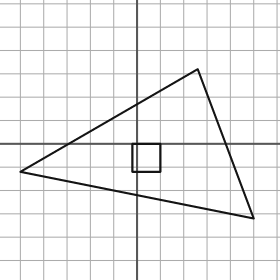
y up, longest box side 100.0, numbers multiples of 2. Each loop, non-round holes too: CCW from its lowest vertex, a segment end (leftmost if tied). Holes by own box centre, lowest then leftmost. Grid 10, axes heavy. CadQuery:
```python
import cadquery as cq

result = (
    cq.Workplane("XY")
    .moveTo(50.0, -32.0)
    .lineTo(26.0, 32.0)
    .lineTo(-50.0, -12.0)
    .close()
    .moveTo(-2.0, -12.0)
    .lineTo(10.0, -12.0)
    .lineTo(10.0, 0.0)
    .lineTo(-2.0, 0.0)
    .close()
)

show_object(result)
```